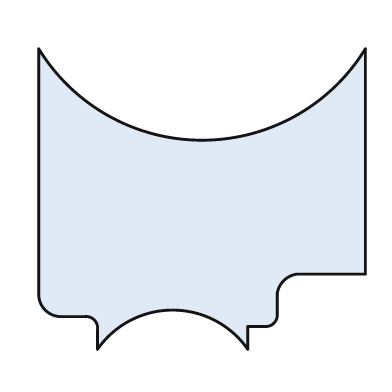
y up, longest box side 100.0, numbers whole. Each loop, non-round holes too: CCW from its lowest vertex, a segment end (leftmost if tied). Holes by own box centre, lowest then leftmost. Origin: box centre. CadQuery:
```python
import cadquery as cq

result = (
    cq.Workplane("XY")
    .moveTo(-32.0, -46.0)
    .threePointArc((-9.0, -34.0), (14.0, -46.0))
    .lineTo(14.0, -39.0)
    .lineTo(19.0, -39.0)
    .threePointArc((22.0, -38.0), (23.0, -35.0))
    .lineTo(23.0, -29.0)
    .threePointArc((25.0, -25.0), (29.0, -23.0))
    .lineTo(50.0, -23.0)
    .lineTo(50.0, 46.0)
    .threePointArc((0.0, 18.0), (-50.0, 46.0))
    .lineTo(-50.0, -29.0)
    .threePointArc((-48.0, -34.0), (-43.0, -36.0))
    .lineTo(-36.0, -36.0)
    .threePointArc((-33.0, -37.0), (-32.0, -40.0))
    .close()
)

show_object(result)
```